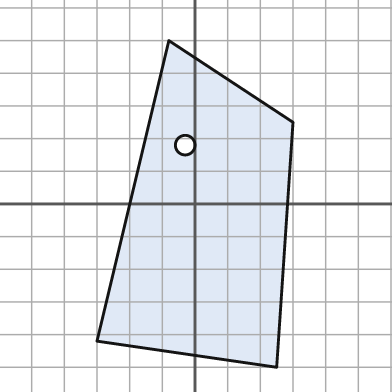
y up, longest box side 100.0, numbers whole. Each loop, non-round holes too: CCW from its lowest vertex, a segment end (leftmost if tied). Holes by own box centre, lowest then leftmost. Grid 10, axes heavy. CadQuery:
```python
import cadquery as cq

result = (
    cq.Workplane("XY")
    .moveTo(25.0, -50.0)
    .lineTo(30.0, 25.0)
    .lineTo(-8.0, 50.0)
    .lineTo(-30.0, -42.0)
    .close()
    .moveTo(-3.0, 18.0)
    .circle(3.0)
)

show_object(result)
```